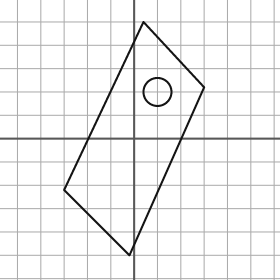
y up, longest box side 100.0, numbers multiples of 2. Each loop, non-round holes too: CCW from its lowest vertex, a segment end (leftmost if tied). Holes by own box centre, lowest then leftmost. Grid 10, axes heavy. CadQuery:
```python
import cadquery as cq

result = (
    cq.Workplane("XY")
    .moveTo(-2.0, -50.0)
    .lineTo(30.0, 22.0)
    .lineTo(4.0, 50.0)
    .lineTo(-30.0, -22.0)
    .close()
    .moveTo(10.0, 20.0)
    .circle(6.0)
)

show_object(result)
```